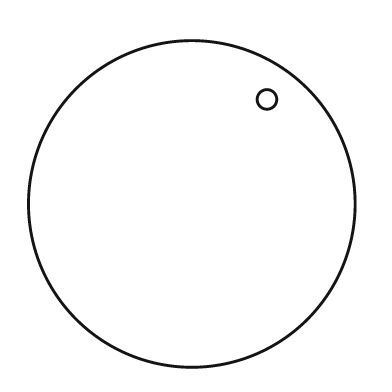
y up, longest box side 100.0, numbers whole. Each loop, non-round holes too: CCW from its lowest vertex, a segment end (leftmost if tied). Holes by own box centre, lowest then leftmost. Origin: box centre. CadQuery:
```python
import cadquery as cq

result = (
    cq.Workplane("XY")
    .moveTo(0.0, 0.0)
    .circle(50.0)
    .moveTo(23.0, 32.0)
    .circle(3.0)
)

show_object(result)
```